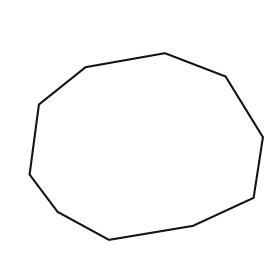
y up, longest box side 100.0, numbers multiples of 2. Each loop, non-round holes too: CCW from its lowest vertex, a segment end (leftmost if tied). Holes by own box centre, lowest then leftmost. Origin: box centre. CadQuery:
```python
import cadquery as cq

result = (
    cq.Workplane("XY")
    .moveTo(-16.0, -40.0)
    .lineTo(20.0, -34.0)
    .lineTo(46.0, -22.0)
    .lineTo(50.0, 4.0)
    .lineTo(34.0, 30.0)
    .lineTo(8.0, 40.0)
    .lineTo(-26.0, 34.0)
    .lineTo(-46.0, 18.0)
    .lineTo(-50.0, -12.0)
    .lineTo(-38.0, -28.0)
    .close()
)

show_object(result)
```